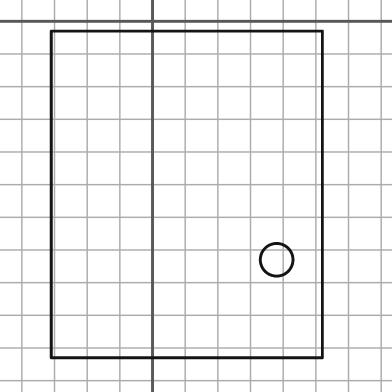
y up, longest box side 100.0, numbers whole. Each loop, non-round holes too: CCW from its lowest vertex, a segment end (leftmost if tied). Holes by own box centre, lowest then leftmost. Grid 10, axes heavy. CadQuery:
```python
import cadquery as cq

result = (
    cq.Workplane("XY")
    .moveTo(-31.0, -103.0)
    .lineTo(52.0, -103.0)
    .lineTo(52.0, -3.0)
    .lineTo(-31.0, -3.0)
    .close()
    .moveTo(38.0, -73.0)
    .circle(5.0)
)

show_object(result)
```